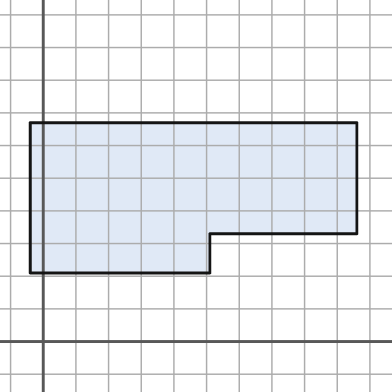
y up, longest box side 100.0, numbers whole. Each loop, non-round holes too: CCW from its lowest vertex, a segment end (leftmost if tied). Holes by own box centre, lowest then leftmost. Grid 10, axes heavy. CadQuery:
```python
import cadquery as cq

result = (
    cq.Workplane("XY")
    .moveTo(-4.0, 21.0)
    .lineTo(51.0, 21.0)
    .lineTo(51.0, 33.0)
    .lineTo(96.0, 33.0)
    .lineTo(96.0, 67.0)
    .lineTo(-4.0, 67.0)
    .close()
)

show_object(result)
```